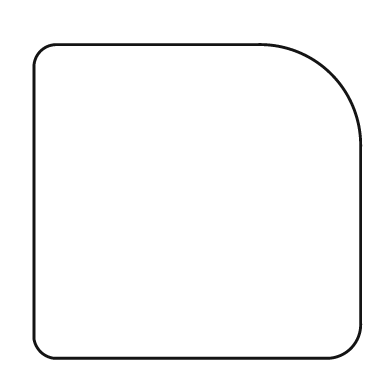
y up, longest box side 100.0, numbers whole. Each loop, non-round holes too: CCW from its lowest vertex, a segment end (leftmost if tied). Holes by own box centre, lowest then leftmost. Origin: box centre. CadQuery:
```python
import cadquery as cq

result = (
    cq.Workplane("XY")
    .moveTo(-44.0, -48.0)
    .lineTo(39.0, -48.0)
    .threePointArc((47.0, -45.0), (50.0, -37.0))
    .lineTo(50.0, 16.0)
    .threePointArc((41.0, 39.0), (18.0, 48.0))
    .lineTo(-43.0, 48.0)
    .threePointArc((-48.0, 46.0), (-50.0, 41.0))
    .lineTo(-50.0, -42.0)
    .threePointArc((-48.0, -46.0), (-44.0, -48.0))
    .close()
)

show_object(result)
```